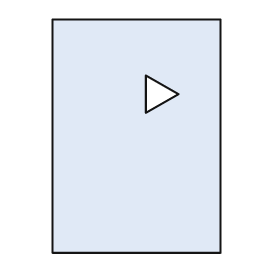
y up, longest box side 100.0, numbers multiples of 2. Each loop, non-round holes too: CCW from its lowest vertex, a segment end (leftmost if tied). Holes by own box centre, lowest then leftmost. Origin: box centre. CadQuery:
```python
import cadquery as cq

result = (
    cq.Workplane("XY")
    .moveTo(-36.0, -50.0)
    .lineTo(36.0, -50.0)
    .lineTo(36.0, 50.0)
    .lineTo(-36.0, 50.0)
    .close()
    .moveTo(4.0, 10.0)
    .lineTo(18.0, 18.0)
    .lineTo(4.0, 26.0)
    .close()
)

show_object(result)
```